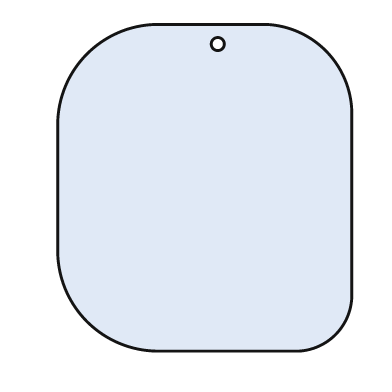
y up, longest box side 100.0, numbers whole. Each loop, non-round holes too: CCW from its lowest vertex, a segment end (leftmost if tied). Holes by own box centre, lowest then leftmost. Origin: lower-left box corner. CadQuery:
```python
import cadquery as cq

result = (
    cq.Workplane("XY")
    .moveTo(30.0, 0.0)
    .lineTo(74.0, 0.0)
    .threePointArc((85.0, 5.0), (90.0, 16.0))
    .lineTo(90.0, 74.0)
    .threePointArc((82.0, 92.0), (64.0, 100.0))
    .lineTo(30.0, 100.0)
    .threePointArc((9.0, 91.0), (0.0, 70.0))
    .lineTo(0.0, 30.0)
    .threePointArc((9.0, 9.0), (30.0, 0.0))
    .close()
    .moveTo(49.0, 94.0)
    .circle(2.0)
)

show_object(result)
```